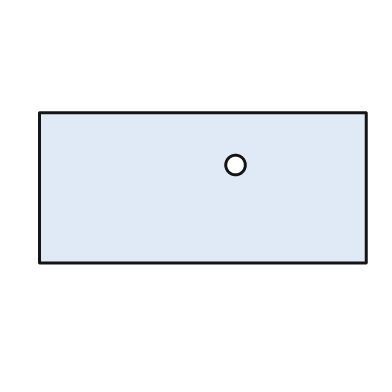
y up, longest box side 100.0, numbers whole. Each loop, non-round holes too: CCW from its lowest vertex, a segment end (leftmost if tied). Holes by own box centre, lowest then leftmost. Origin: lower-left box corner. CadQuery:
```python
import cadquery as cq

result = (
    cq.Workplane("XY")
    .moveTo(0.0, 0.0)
    .lineTo(100.0, 0.0)
    .lineTo(100.0, 46.0)
    .lineTo(0.0, 46.0)
    .close()
    .moveTo(60.0, 30.0)
    .circle(3.0)
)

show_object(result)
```